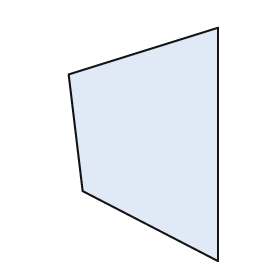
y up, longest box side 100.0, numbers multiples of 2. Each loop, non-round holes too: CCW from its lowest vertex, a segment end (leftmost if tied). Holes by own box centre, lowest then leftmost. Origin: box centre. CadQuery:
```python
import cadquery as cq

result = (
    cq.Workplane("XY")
    .moveTo(32.0, -50.0)
    .lineTo(32.0, 50.0)
    .lineTo(-32.0, 30.0)
    .lineTo(-26.0, -20.0)
    .close()
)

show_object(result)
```